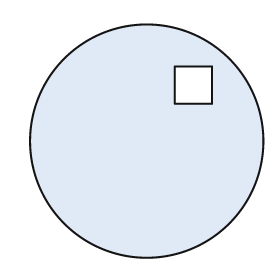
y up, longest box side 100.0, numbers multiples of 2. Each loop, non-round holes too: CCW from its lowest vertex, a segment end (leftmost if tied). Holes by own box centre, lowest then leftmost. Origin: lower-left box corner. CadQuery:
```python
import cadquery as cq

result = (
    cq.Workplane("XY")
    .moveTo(50.0, 50.0)
    .circle(50.0)
    .moveTo(62.0, 66.0)
    .lineTo(78.0, 66.0)
    .lineTo(78.0, 82.0)
    .lineTo(62.0, 82.0)
    .close()
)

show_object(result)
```